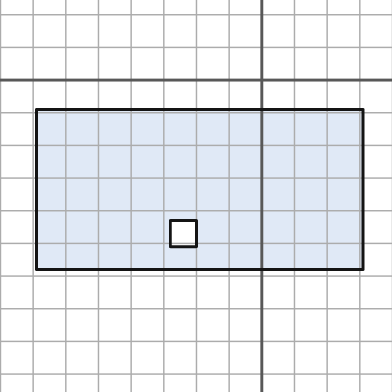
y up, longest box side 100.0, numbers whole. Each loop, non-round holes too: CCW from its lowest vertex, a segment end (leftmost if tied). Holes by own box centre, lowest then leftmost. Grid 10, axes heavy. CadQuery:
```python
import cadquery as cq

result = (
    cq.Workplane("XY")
    .moveTo(-69.0, -58.0)
    .lineTo(31.0, -58.0)
    .lineTo(31.0, -9.0)
    .lineTo(-69.0, -9.0)
    .close()
    .moveTo(-28.0, -51.0)
    .lineTo(-20.0, -51.0)
    .lineTo(-20.0, -43.0)
    .lineTo(-28.0, -43.0)
    .close()
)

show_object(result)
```